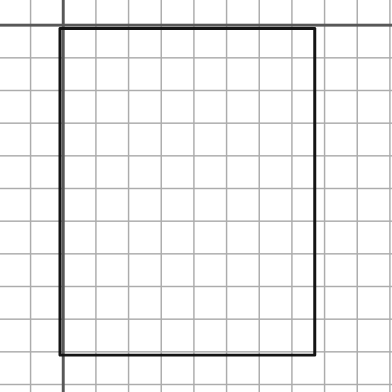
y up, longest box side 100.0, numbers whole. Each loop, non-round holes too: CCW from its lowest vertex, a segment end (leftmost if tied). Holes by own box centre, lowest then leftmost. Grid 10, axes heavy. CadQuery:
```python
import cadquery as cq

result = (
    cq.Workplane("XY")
    .moveTo(-1.0, -101.0)
    .lineTo(77.0, -101.0)
    .lineTo(77.0, -1.0)
    .lineTo(-1.0, -1.0)
    .close()
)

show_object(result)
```